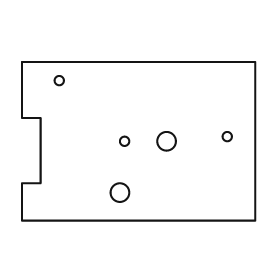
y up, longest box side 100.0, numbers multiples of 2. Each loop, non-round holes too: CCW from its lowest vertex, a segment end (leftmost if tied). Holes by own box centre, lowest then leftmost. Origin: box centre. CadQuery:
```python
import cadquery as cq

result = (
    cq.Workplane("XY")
    .moveTo(-50.0, -34.0)
    .lineTo(50.0, -34.0)
    .lineTo(50.0, 34.0)
    .lineTo(-50.0, 34.0)
    .lineTo(-50.0, 10.0)
    .lineTo(-42.0, 10.0)
    .lineTo(-42.0, -18.0)
    .lineTo(-50.0, -18.0)
    .close()
    .moveTo(-8.0, -22.0)
    .circle(4.0)
    .moveTo(-6.0, 0.0)
    .circle(2.0)
    .moveTo(12.0, 0.0)
    .circle(4.0)
    .moveTo(38.0, 2.0)
    .circle(2.0)
    .moveTo(-34.0, 26.0)
    .circle(2.0)
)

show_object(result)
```